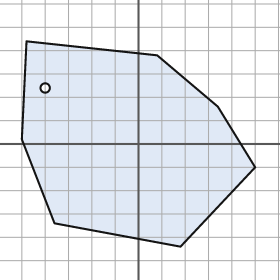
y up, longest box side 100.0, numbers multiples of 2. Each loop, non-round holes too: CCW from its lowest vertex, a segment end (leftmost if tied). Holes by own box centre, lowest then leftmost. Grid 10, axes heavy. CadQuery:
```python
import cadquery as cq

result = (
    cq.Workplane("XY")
    .moveTo(18.0, -44.0)
    .lineTo(50.0, -10.0)
    .lineTo(34.0, 16.0)
    .lineTo(8.0, 38.0)
    .lineTo(-48.0, 44.0)
    .lineTo(-50.0, 2.0)
    .lineTo(-36.0, -34.0)
    .close()
    .moveTo(-40.0, 24.0)
    .circle(2.0)
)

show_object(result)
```